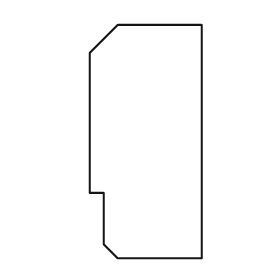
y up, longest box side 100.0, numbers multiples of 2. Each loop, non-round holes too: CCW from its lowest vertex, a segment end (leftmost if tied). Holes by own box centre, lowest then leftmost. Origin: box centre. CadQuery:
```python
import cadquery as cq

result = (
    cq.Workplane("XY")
    .moveTo(-12.0, -50.0)
    .lineTo(24.0, -50.0)
    .lineTo(24.0, 50.0)
    .lineTo(-12.0, 50.0)
    .lineTo(-24.0, 38.0)
    .lineTo(-24.0, -22.0)
    .lineTo(-18.0, -22.0)
    .lineTo(-18.0, -44.0)
    .close()
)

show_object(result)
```